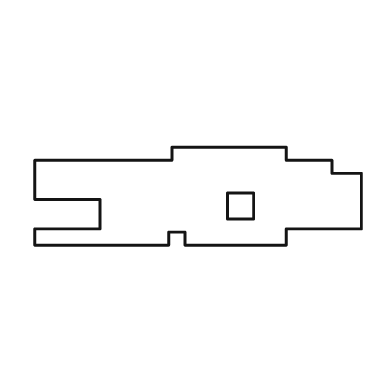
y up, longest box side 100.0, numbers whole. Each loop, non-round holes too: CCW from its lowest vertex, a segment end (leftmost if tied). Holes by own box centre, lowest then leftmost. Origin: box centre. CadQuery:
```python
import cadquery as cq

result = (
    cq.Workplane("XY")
    .moveTo(-50.0, -15.0)
    .lineTo(-9.0, -15.0)
    .lineTo(-9.0, -11.0)
    .lineTo(-4.0, -11.0)
    .lineTo(-4.0, -15.0)
    .lineTo(27.0, -15.0)
    .lineTo(27.0, -10.0)
    .lineTo(50.0, -10.0)
    .lineTo(50.0, 7.0)
    .lineTo(41.0, 7.0)
    .lineTo(41.0, 11.0)
    .lineTo(27.0, 11.0)
    .lineTo(27.0, 15.0)
    .lineTo(-8.0, 15.0)
    .lineTo(-8.0, 11.0)
    .lineTo(-50.0, 11.0)
    .lineTo(-50.0, -1.0)
    .lineTo(-30.0, -1.0)
    .lineTo(-30.0, -10.0)
    .lineTo(-50.0, -10.0)
    .close()
    .moveTo(9.0, -7.0)
    .lineTo(17.0, -7.0)
    .lineTo(17.0, 1.0)
    .lineTo(9.0, 1.0)
    .close()
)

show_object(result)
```